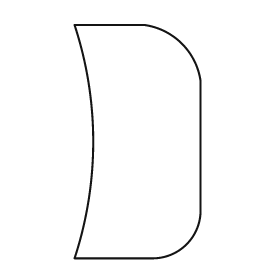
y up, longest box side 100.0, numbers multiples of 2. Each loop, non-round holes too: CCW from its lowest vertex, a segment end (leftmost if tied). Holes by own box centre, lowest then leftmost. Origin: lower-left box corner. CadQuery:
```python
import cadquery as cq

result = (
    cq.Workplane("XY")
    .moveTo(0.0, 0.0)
    .lineTo(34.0, 0.0)
    .threePointArc((48.0, 6.0), (54.0, 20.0))
    .lineTo(54.0, 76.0)
    .threePointArc((46.0, 92.0), (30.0, 100.0))
    .lineTo(0.0, 100.0)
    .threePointArc((8.0, 50.0), (0.0, 0.0))
    .close()
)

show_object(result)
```